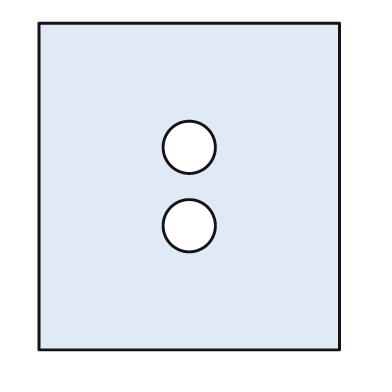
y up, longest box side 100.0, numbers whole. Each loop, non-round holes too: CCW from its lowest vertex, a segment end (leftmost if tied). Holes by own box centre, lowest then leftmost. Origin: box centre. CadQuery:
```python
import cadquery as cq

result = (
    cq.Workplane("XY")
    .moveTo(-46.0, -50.0)
    .lineTo(46.0, -50.0)
    .lineTo(46.0, 50.0)
    .lineTo(-46.0, 50.0)
    .close()
    .moveTo(0.0, -12.0)
    .circle(8.0)
    .moveTo(0.0, 12.0)
    .circle(8.0)
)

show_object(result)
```